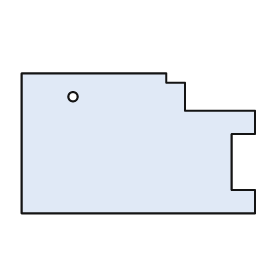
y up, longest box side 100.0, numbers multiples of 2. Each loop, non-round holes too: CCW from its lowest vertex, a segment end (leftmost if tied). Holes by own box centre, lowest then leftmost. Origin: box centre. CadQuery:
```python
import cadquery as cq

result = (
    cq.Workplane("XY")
    .moveTo(-50.0, -30.0)
    .lineTo(50.0, -30.0)
    .lineTo(50.0, -20.0)
    .lineTo(40.0, -20.0)
    .lineTo(40.0, 4.0)
    .lineTo(50.0, 4.0)
    .lineTo(50.0, 14.0)
    .lineTo(20.0, 14.0)
    .lineTo(20.0, 26.0)
    .lineTo(12.0, 26.0)
    .lineTo(12.0, 30.0)
    .lineTo(-50.0, 30.0)
    .close()
    .moveTo(-28.0, 20.0)
    .circle(2.0)
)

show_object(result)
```